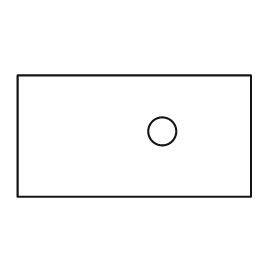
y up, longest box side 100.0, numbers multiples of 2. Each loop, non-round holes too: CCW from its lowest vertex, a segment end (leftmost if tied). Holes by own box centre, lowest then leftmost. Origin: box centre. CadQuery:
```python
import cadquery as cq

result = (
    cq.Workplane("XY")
    .moveTo(-50.0, -26.0)
    .lineTo(50.0, -26.0)
    .lineTo(50.0, 26.0)
    .lineTo(-50.0, 26.0)
    .close()
    .moveTo(12.0, 2.0)
    .circle(6.0)
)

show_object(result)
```